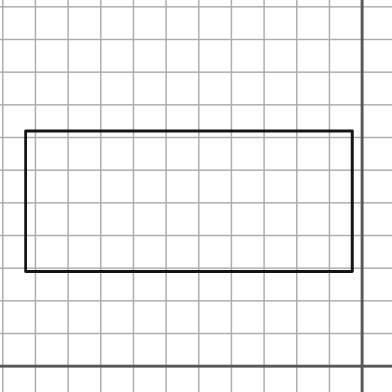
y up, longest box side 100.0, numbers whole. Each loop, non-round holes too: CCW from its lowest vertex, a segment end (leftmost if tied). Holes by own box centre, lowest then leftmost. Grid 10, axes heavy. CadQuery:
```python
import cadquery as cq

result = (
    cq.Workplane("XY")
    .moveTo(-103.0, 29.0)
    .lineTo(-3.0, 29.0)
    .lineTo(-3.0, 72.0)
    .lineTo(-103.0, 72.0)
    .close()
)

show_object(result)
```